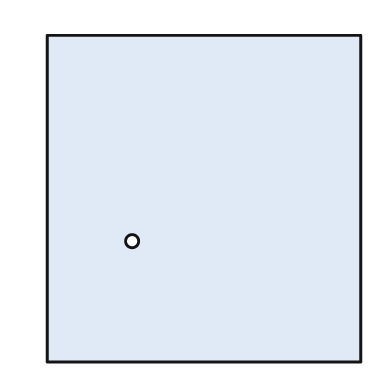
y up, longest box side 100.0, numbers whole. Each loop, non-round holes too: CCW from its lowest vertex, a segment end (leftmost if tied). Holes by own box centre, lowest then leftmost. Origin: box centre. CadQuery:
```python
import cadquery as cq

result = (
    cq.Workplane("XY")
    .moveTo(-48.0, -50.0)
    .lineTo(48.0, -50.0)
    .lineTo(48.0, 50.0)
    .lineTo(-48.0, 50.0)
    .close()
    .moveTo(-22.0, -13.0)
    .circle(2.0)
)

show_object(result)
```